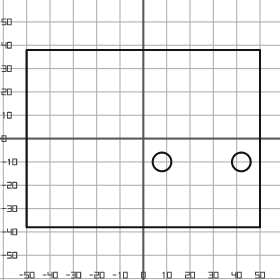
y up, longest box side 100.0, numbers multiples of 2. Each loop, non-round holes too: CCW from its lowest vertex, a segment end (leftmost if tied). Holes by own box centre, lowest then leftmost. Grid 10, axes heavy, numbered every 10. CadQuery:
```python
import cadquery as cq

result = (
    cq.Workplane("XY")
    .moveTo(-50.0, -38.0)
    .lineTo(50.0, -38.0)
    .lineTo(50.0, 38.0)
    .lineTo(-50.0, 38.0)
    .close()
    .moveTo(8.0, -10.0)
    .circle(4.0)
    .moveTo(42.0, -10.0)
    .circle(4.0)
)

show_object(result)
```